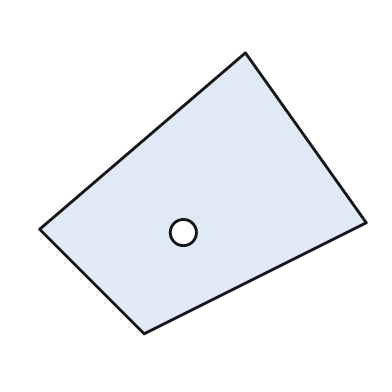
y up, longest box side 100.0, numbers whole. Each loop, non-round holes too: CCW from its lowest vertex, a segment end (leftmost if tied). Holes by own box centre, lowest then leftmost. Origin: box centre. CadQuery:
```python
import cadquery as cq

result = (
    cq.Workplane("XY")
    .moveTo(-18.0, -43.0)
    .lineTo(50.0, -9.0)
    .lineTo(13.0, 43.0)
    .lineTo(-50.0, -11.0)
    .close()
    .moveTo(-6.0, -12.0)
    .circle(4.0)
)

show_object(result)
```